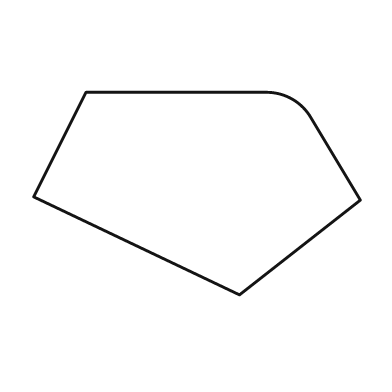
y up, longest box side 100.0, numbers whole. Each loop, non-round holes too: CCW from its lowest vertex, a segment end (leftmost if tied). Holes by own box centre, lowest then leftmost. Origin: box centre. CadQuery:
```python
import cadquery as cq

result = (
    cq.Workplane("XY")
    .moveTo(13.0, -31.0)
    .lineTo(50.0, -2.0)
    .lineTo(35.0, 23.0)
    .threePointArc((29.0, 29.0), (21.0, 31.0))
    .lineTo(-34.0, 31.0)
    .lineTo(-50.0, -1.0)
    .close()
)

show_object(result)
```